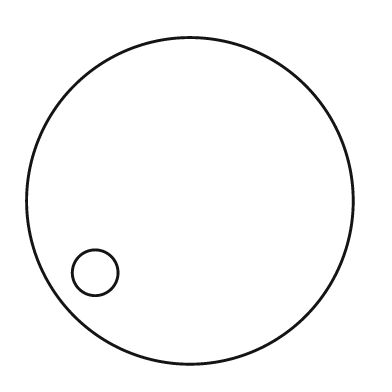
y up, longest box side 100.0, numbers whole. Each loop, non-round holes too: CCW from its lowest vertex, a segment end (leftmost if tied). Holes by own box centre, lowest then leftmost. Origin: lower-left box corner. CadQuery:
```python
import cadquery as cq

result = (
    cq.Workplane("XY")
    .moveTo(50.0, 50.0)
    .circle(50.0)
    .moveTo(21.0, 28.0)
    .circle(7.0)
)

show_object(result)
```